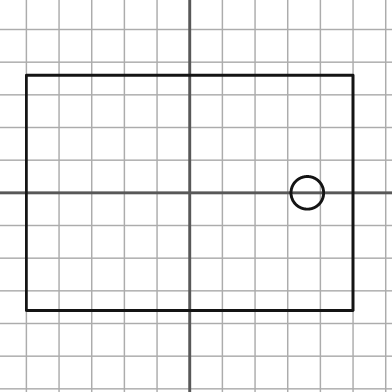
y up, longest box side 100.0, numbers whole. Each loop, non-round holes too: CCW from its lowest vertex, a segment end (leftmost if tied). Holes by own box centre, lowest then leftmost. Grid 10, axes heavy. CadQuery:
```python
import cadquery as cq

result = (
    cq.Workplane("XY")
    .moveTo(-50.0, -36.0)
    .lineTo(50.0, -36.0)
    .lineTo(50.0, 36.0)
    .lineTo(-50.0, 36.0)
    .close()
    .moveTo(36.0, 0.0)
    .circle(5.0)
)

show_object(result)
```